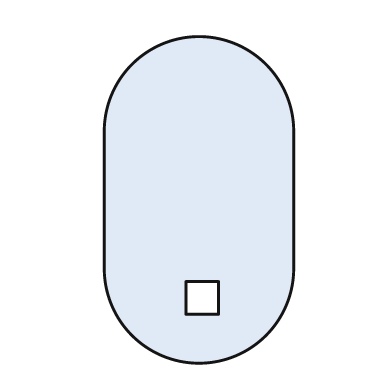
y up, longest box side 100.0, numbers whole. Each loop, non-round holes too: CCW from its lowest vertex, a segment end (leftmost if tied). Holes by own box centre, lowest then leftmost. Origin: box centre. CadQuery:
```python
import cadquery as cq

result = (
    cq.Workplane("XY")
    .moveTo(-29.0, -21.0)
    .threePointArc((0.0, -50.0), (29.0, -21.0))
    .lineTo(29.0, 21.0)
    .threePointArc((0.0, 50.0), (-29.0, 21.0))
    .close()
    .moveTo(-4.0, -35.0)
    .lineTo(6.0, -35.0)
    .lineTo(6.0, -25.0)
    .lineTo(-4.0, -25.0)
    .close()
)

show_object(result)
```